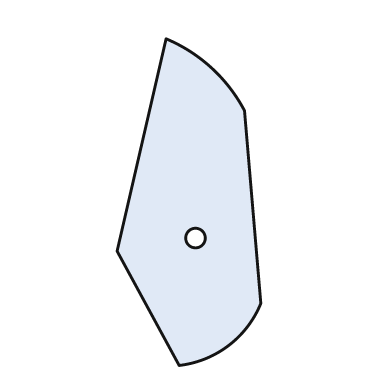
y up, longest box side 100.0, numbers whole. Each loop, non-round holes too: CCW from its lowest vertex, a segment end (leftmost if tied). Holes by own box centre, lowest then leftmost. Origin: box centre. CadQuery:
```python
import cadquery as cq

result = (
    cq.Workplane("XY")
    .moveTo(-3.0, -50.0)
    .threePointArc((12.0, -44.0), (22.0, -31.0))
    .lineTo(17.0, 28.0)
    .threePointArc((7.0, 41.0), (-7.0, 50.0))
    .lineTo(-22.0, -15.0)
    .close()
    .moveTo(2.0, -11.0)
    .circle(3.0)
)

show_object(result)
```